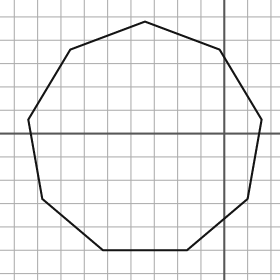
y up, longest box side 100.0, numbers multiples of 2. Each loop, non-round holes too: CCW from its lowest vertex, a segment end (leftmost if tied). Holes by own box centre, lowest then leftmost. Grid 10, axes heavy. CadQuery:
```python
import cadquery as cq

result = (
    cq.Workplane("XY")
    .moveTo(-52.0, -50.0)
    .lineTo(-16.0, -50.0)
    .lineTo(10.0, -28.0)
    .lineTo(16.0, 6.0)
    .lineTo(-2.0, 36.0)
    .lineTo(-34.0, 48.0)
    .lineTo(-66.0, 36.0)
    .lineTo(-84.0, 6.0)
    .lineTo(-78.0, -28.0)
    .close()
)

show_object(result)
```